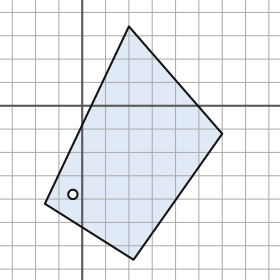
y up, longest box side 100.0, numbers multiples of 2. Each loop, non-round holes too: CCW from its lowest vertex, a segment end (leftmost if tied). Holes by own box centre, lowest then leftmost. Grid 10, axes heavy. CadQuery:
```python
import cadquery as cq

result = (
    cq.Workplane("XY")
    .moveTo(22.0, -66.0)
    .lineTo(60.0, -12.0)
    .lineTo(20.0, 34.0)
    .lineTo(-16.0, -42.0)
    .close()
    .moveTo(-4.0, -38.0)
    .circle(2.0)
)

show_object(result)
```